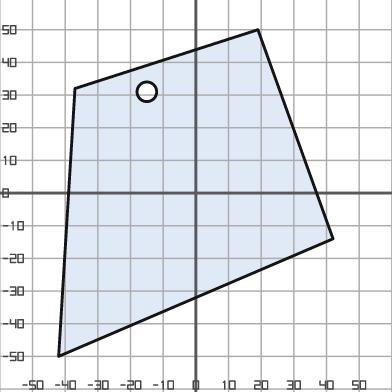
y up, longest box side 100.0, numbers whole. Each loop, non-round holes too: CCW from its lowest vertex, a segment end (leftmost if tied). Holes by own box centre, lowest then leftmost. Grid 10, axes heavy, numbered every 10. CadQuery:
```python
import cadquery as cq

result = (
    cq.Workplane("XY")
    .moveTo(-42.0, -50.0)
    .lineTo(42.0, -14.0)
    .lineTo(19.0, 50.0)
    .lineTo(-37.0, 32.0)
    .close()
    .moveTo(-15.0, 31.0)
    .circle(3.0)
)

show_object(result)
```